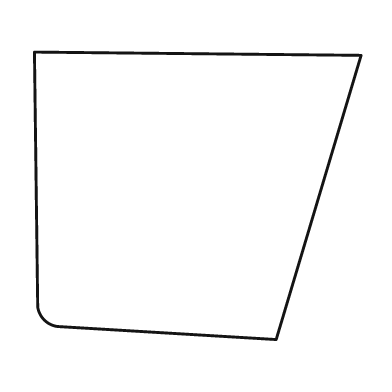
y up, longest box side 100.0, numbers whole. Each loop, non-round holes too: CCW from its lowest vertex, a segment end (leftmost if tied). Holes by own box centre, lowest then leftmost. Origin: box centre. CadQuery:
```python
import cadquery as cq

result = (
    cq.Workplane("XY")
    .moveTo(24.0, -44.0)
    .lineTo(50.0, 43.0)
    .lineTo(-50.0, 44.0)
    .lineTo(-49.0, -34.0)
    .threePointArc((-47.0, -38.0), (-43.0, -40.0))
    .close()
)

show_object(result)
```